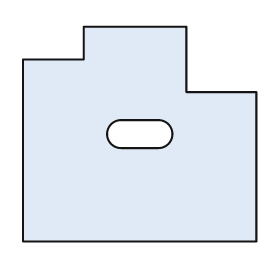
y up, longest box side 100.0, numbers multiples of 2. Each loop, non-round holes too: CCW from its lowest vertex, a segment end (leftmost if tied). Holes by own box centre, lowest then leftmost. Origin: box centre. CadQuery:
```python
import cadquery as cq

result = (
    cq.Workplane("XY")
    .moveTo(-50.0, -46.0)
    .lineTo(50.0, -46.0)
    .lineTo(50.0, 18.0)
    .lineTo(20.0, 18.0)
    .lineTo(20.0, 46.0)
    .lineTo(-24.0, 46.0)
    .lineTo(-24.0, 32.0)
    .lineTo(-50.0, 32.0)
    .close()
    .moveTo(-8.0, -6.0)
    .lineTo(8.0, -6.0)
    .threePointArc((14.0, 0.0), (8.0, 6.0))
    .lineTo(-8.0, 6.0)
    .threePointArc((-14.0, 0.0), (-8.0, -6.0))
    .close()
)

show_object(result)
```